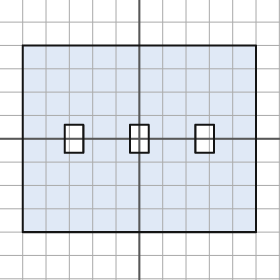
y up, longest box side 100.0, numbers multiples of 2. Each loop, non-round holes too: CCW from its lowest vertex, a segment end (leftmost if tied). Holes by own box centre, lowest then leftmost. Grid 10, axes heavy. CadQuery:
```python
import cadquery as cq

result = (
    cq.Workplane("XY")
    .moveTo(-50.0, -40.0)
    .lineTo(50.0, -40.0)
    .lineTo(50.0, 40.0)
    .lineTo(-50.0, 40.0)
    .close()
    .moveTo(-32.0, -6.0)
    .lineTo(-24.0, -6.0)
    .lineTo(-24.0, 6.0)
    .lineTo(-32.0, 6.0)
    .close()
    .moveTo(-4.0, -6.0)
    .lineTo(4.0, -6.0)
    .lineTo(4.0, 6.0)
    .lineTo(-4.0, 6.0)
    .close()
    .moveTo(24.0, -6.0)
    .lineTo(32.0, -6.0)
    .lineTo(32.0, 6.0)
    .lineTo(24.0, 6.0)
    .close()
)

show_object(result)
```